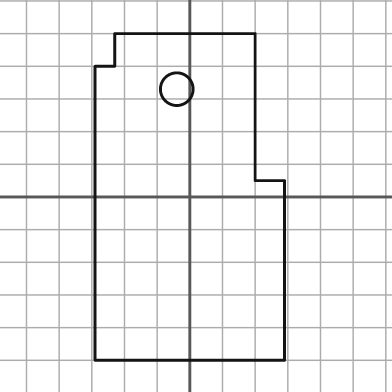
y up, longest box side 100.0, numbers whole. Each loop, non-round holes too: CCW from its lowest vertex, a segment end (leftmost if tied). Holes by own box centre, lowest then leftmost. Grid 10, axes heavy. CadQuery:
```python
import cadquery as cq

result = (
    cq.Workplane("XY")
    .moveTo(-29.0, -50.0)
    .lineTo(29.0, -50.0)
    .lineTo(29.0, 5.0)
    .lineTo(20.0, 5.0)
    .lineTo(20.0, 50.0)
    .lineTo(-23.0, 50.0)
    .lineTo(-23.0, 40.0)
    .lineTo(-29.0, 40.0)
    .close()
    .moveTo(-4.0, 33.0)
    .circle(5.0)
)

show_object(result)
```